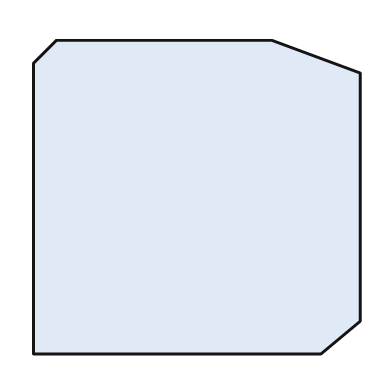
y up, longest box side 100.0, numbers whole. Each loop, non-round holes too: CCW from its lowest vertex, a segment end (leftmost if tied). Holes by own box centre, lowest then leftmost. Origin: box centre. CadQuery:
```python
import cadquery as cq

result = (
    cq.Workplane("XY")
    .moveTo(-50.0, -48.0)
    .lineTo(38.0, -48.0)
    .lineTo(50.0, -38.0)
    .lineTo(50.0, 38.0)
    .lineTo(23.0, 48.0)
    .lineTo(-43.0, 48.0)
    .lineTo(-50.0, 41.0)
    .close()
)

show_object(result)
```